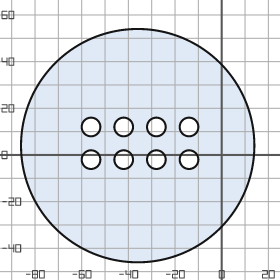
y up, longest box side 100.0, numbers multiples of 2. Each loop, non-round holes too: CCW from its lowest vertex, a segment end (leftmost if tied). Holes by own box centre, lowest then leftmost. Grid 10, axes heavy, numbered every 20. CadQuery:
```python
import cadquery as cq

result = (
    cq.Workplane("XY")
    .moveTo(-36.0, 4.0)
    .circle(50.0)
    .moveTo(-56.0, -2.0)
    .circle(4.0)
    .moveTo(-42.0, -2.0)
    .circle(4.0)
    .moveTo(-28.0, -2.0)
    .circle(4.0)
    .moveTo(-14.0, -2.0)
    .circle(4.0)
    .moveTo(-56.0, 12.0)
    .circle(4.0)
    .moveTo(-42.0, 12.0)
    .circle(4.0)
    .moveTo(-28.0, 12.0)
    .circle(4.0)
    .moveTo(-14.0, 12.0)
    .circle(4.0)
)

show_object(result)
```